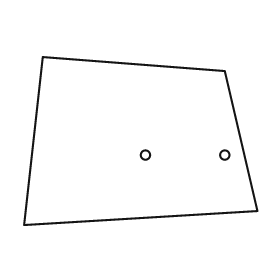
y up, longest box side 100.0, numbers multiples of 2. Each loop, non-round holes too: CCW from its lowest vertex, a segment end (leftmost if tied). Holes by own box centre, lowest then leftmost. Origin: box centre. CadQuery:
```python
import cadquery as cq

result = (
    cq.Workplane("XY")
    .moveTo(-50.0, -36.0)
    .lineTo(50.0, -30.0)
    .lineTo(36.0, 30.0)
    .lineTo(-42.0, 36.0)
    .close()
    .moveTo(2.0, -6.0)
    .circle(2.0)
    .moveTo(36.0, -6.0)
    .circle(2.0)
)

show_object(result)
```